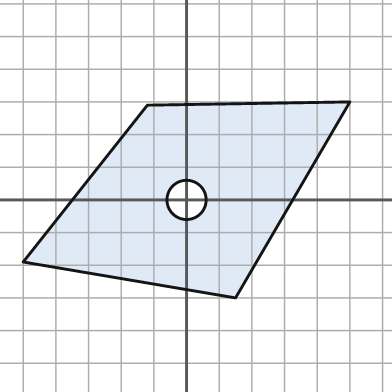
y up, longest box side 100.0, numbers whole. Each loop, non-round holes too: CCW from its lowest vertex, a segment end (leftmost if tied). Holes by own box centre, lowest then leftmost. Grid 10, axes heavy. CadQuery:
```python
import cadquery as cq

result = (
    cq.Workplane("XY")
    .moveTo(15.0, -30.0)
    .lineTo(50.0, 30.0)
    .lineTo(-12.0, 29.0)
    .lineTo(-50.0, -19.0)
    .close()
    .moveTo(0.0, 0.0)
    .circle(6.0)
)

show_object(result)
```